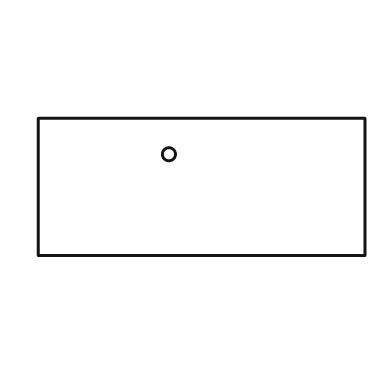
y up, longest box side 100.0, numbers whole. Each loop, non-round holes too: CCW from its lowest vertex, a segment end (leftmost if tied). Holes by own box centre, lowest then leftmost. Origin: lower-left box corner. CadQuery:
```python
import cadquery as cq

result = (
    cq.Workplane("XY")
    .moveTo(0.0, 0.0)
    .lineTo(100.0, 0.0)
    .lineTo(100.0, 42.0)
    .lineTo(0.0, 42.0)
    .close()
    .moveTo(40.0, 31.0)
    .circle(2.0)
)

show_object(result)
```